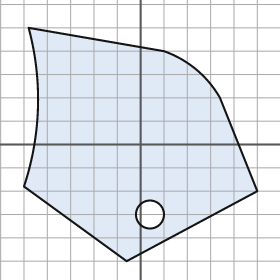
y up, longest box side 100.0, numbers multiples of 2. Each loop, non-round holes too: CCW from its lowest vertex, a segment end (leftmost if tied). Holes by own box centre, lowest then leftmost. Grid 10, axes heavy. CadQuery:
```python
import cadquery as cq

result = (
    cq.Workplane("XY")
    .moveTo(-6.0, -50.0)
    .lineTo(50.0, -20.0)
    .lineTo(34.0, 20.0)
    .threePointArc((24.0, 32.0), (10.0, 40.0))
    .lineTo(-48.0, 50.0)
    .threePointArc((-44.0, 16.0), (-50.0, -18.0))
    .close()
    .moveTo(4.0, -30.0)
    .circle(6.0)
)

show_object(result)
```